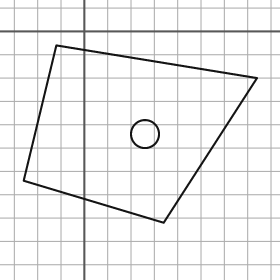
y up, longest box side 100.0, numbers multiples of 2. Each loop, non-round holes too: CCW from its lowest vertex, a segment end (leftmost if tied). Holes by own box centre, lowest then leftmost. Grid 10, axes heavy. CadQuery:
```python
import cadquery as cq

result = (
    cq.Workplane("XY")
    .moveTo(34.0, -82.0)
    .lineTo(74.0, -20.0)
    .lineTo(-12.0, -6.0)
    .lineTo(-26.0, -64.0)
    .close()
    .moveTo(26.0, -44.0)
    .circle(6.0)
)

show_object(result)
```